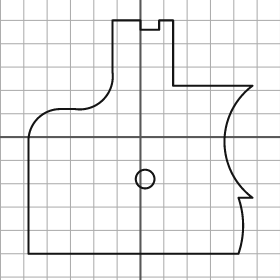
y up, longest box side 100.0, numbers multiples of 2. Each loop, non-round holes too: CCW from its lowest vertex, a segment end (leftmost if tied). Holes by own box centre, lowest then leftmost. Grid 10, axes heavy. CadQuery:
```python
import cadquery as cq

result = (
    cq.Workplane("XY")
    .moveTo(-48.0, -50.0)
    .lineTo(42.0, -50.0)
    .threePointArc((44.0, -38.0), (42.0, -26.0))
    .lineTo(48.0, -26.0)
    .threePointArc((36.0, -2.0), (48.0, 22.0))
    .lineTo(14.0, 22.0)
    .lineTo(14.0, 50.0)
    .lineTo(8.0, 50.0)
    .lineTo(8.0, 46.0)
    .lineTo(0.0, 46.0)
    .lineTo(0.0, 50.0)
    .lineTo(-12.0, 50.0)
    .lineTo(-12.0, 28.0)
    .threePointArc((-16.0, 16.0), (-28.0, 12.0))
    .lineTo(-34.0, 12.0)
    .threePointArc((-44.0, 8.0), (-48.0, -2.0))
    .close()
    .moveTo(2.0, -18.0)
    .circle(4.0)
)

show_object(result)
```